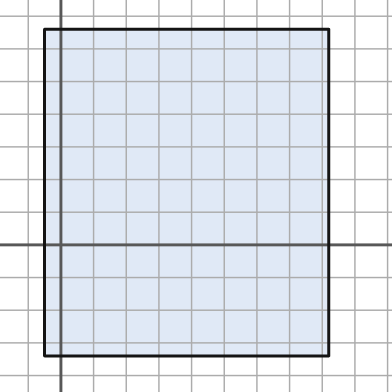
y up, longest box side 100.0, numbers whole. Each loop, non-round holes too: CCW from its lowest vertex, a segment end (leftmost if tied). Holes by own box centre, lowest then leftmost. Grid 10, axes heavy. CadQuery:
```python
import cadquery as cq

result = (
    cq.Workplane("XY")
    .moveTo(-5.0, -34.0)
    .lineTo(82.0, -34.0)
    .lineTo(82.0, 66.0)
    .lineTo(-5.0, 66.0)
    .close()
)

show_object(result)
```